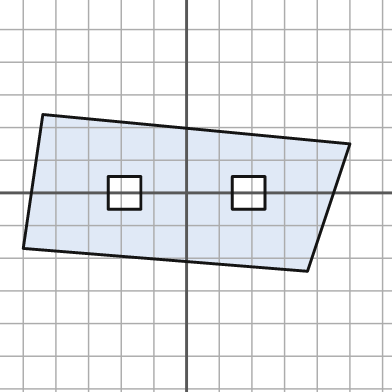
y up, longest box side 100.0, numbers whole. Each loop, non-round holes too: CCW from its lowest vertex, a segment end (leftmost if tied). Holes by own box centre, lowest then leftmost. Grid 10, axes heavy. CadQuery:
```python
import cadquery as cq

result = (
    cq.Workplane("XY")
    .moveTo(37.0, -24.0)
    .lineTo(50.0, 15.0)
    .lineTo(-44.0, 24.0)
    .lineTo(-50.0, -17.0)
    .close()
    .moveTo(-24.0, -5.0)
    .lineTo(-14.0, -5.0)
    .lineTo(-14.0, 5.0)
    .lineTo(-24.0, 5.0)
    .close()
    .moveTo(14.0, -5.0)
    .lineTo(24.0, -5.0)
    .lineTo(24.0, 5.0)
    .lineTo(14.0, 5.0)
    .close()
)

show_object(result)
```